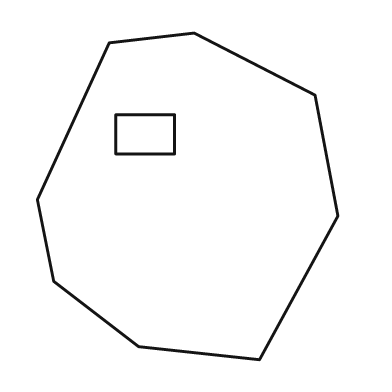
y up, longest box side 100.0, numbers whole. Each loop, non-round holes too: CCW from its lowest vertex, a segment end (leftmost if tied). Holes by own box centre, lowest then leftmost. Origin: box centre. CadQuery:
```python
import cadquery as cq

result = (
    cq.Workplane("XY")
    .moveTo(22.0, -50.0)
    .lineTo(46.0, -6.0)
    .lineTo(39.0, 31.0)
    .lineTo(2.0, 50.0)
    .lineTo(-24.0, 47.0)
    .lineTo(-46.0, -1.0)
    .lineTo(-41.0, -26.0)
    .lineTo(-15.0, -46.0)
    .close()
    .moveTo(-22.0, 13.0)
    .lineTo(-4.0, 13.0)
    .lineTo(-4.0, 25.0)
    .lineTo(-22.0, 25.0)
    .close()
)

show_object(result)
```